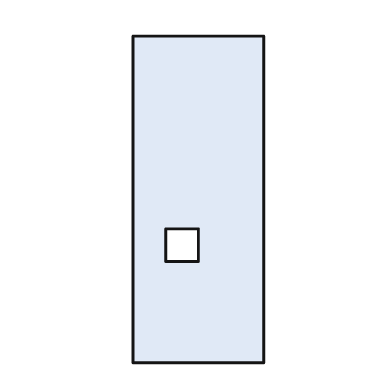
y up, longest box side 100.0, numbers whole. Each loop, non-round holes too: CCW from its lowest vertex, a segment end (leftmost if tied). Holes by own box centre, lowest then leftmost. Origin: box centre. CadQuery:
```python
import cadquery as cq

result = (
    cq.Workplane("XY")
    .moveTo(-20.0, -50.0)
    .lineTo(20.0, -50.0)
    .lineTo(20.0, 50.0)
    .lineTo(-20.0, 50.0)
    .close()
    .moveTo(-10.0, -19.0)
    .lineTo(0.0, -19.0)
    .lineTo(0.0, -9.0)
    .lineTo(-10.0, -9.0)
    .close()
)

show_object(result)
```